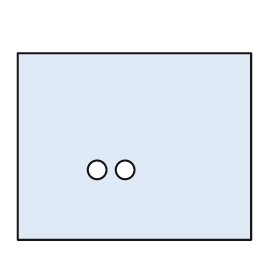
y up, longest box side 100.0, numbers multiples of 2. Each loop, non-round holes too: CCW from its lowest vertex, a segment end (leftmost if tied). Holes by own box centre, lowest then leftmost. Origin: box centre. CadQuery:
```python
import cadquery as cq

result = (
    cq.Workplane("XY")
    .moveTo(-50.0, -40.0)
    .lineTo(50.0, -40.0)
    .lineTo(50.0, 40.0)
    .lineTo(-50.0, 40.0)
    .close()
    .moveTo(-16.0, -10.0)
    .circle(4.0)
    .moveTo(-4.0, -10.0)
    .circle(4.0)
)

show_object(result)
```